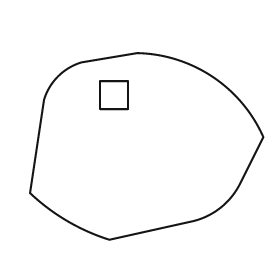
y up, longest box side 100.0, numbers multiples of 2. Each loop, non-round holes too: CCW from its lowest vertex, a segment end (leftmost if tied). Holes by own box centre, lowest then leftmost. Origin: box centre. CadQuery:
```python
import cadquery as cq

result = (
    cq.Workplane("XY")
    .moveTo(-16.0, -40.0)
    .lineTo(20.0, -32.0)
    .threePointArc((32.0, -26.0), (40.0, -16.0))
    .lineTo(50.0, 4.0)
    .threePointArc((28.0, 30.0), (-4.0, 40.0))
    .lineTo(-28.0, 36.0)
    .threePointArc((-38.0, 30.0), (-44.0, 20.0))
    .lineTo(-50.0, -20.0)
    .threePointArc((-34.0, -32.0), (-16.0, -40.0))
    .close()
    .moveTo(-20.0, 16.0)
    .lineTo(-8.0, 16.0)
    .lineTo(-8.0, 28.0)
    .lineTo(-20.0, 28.0)
    .close()
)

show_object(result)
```